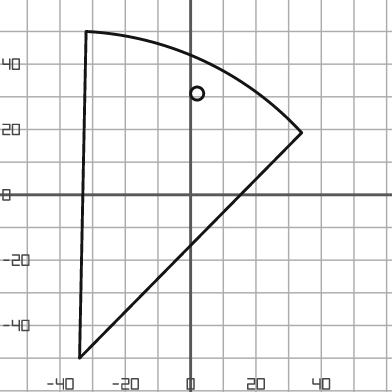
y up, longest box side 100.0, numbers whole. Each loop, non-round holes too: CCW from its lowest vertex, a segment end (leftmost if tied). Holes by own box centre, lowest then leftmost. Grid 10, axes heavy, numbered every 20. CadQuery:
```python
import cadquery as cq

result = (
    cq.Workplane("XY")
    .moveTo(-34.0, -50.0)
    .lineTo(34.0, 19.0)
    .threePointArc((4.0, 41.0), (-32.0, 50.0))
    .close()
    .moveTo(2.0, 31.0)
    .circle(2.0)
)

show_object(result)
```